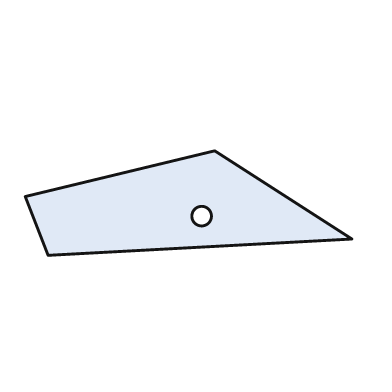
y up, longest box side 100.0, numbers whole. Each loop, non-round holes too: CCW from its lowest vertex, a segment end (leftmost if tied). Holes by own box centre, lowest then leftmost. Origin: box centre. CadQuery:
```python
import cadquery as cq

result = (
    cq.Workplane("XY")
    .moveTo(-43.0, -16.0)
    .lineTo(50.0, -11.0)
    .lineTo(8.0, 16.0)
    .lineTo(-50.0, 2.0)
    .close()
    .moveTo(4.0, -4.0)
    .circle(3.0)
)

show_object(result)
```